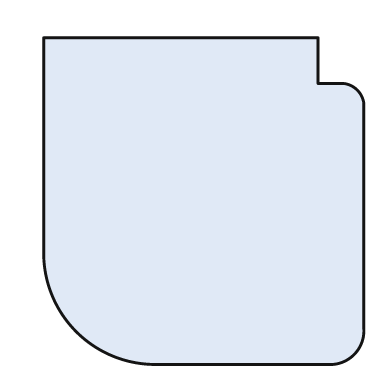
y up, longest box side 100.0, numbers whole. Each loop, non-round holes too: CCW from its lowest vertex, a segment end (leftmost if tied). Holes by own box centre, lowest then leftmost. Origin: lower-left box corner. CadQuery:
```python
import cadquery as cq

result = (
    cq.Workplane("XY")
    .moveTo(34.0, 0.0)
    .lineTo(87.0, 0.0)
    .threePointArc((95.0, 3.0), (98.0, 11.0))
    .lineTo(98.0, 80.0)
    .threePointArc((96.0, 84.0), (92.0, 86.0))
    .lineTo(84.0, 86.0)
    .lineTo(84.0, 100.0)
    .lineTo(0.0, 100.0)
    .lineTo(0.0, 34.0)
    .threePointArc((10.0, 10.0), (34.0, 0.0))
    .close()
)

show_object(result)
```